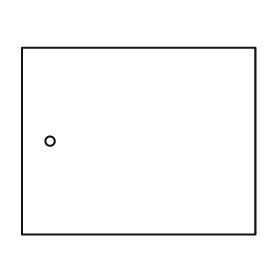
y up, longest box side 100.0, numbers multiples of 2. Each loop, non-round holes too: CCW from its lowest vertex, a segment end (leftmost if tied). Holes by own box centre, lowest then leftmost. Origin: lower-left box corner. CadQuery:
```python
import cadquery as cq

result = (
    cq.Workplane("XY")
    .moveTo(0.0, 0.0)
    .lineTo(100.0, 0.0)
    .lineTo(100.0, 80.0)
    .lineTo(0.0, 80.0)
    .close()
    .moveTo(12.0, 40.0)
    .circle(2.0)
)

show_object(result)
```